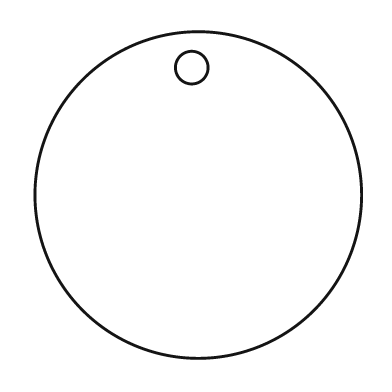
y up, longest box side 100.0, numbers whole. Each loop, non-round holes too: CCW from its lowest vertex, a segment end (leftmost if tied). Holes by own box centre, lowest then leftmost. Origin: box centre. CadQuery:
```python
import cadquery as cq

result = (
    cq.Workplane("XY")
    .moveTo(0.0, 0.0)
    .circle(50.0)
    .moveTo(-2.0, 39.0)
    .circle(5.0)
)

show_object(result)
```